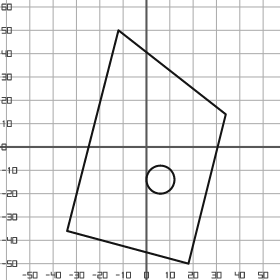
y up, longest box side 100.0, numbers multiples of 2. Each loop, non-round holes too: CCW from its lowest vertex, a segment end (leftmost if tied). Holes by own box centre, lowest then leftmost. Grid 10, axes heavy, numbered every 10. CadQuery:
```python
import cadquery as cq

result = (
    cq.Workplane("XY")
    .moveTo(18.0, -50.0)
    .lineTo(34.0, 14.0)
    .lineTo(-12.0, 50.0)
    .lineTo(-34.0, -36.0)
    .close()
    .moveTo(6.0, -14.0)
    .circle(6.0)
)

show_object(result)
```